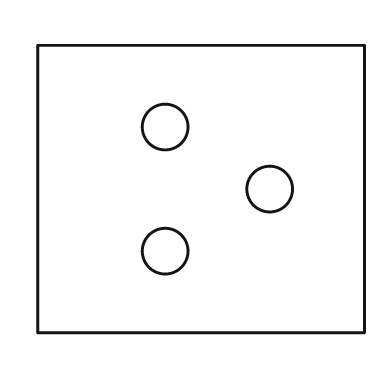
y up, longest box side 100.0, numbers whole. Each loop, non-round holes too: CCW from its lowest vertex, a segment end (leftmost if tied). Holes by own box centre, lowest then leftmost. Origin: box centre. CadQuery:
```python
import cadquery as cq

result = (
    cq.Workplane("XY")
    .moveTo(-50.0, -44.0)
    .lineTo(50.0, -44.0)
    .lineTo(50.0, 44.0)
    .lineTo(-50.0, 44.0)
    .close()
    .moveTo(-11.0, -19.0)
    .circle(7.0)
    .moveTo(21.0, 0.0)
    .circle(7.0)
    .moveTo(-11.0, 19.0)
    .circle(7.0)
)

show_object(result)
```